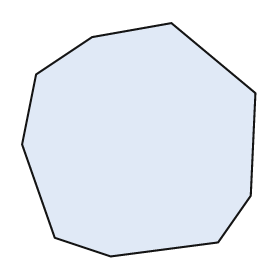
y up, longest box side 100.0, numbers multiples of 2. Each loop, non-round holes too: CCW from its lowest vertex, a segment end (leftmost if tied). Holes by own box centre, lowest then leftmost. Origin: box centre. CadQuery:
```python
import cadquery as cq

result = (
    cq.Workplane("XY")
    .moveTo(-12.0, -50.0)
    .lineTo(34.0, -44.0)
    .lineTo(48.0, -24.0)
    .lineTo(50.0, 20.0)
    .lineTo(14.0, 50.0)
    .lineTo(-20.0, 44.0)
    .lineTo(-44.0, 28.0)
    .lineTo(-50.0, -2.0)
    .lineTo(-36.0, -42.0)
    .close()
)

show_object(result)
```